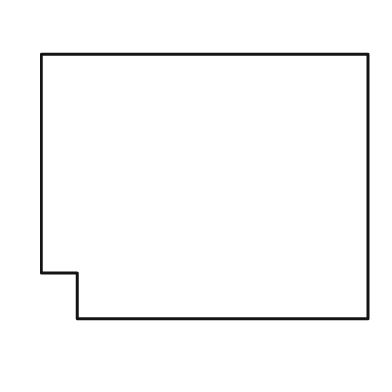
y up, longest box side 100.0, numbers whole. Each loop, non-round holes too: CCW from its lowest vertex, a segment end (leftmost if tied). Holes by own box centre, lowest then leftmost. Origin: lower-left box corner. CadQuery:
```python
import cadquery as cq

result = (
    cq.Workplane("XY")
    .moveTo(11.0, 0.0)
    .lineTo(100.0, 0.0)
    .lineTo(100.0, 81.0)
    .lineTo(0.0, 81.0)
    .lineTo(0.0, 14.0)
    .lineTo(11.0, 14.0)
    .close()
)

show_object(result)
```